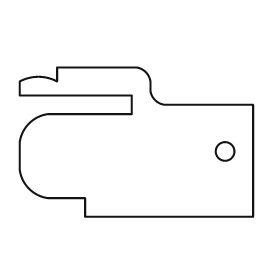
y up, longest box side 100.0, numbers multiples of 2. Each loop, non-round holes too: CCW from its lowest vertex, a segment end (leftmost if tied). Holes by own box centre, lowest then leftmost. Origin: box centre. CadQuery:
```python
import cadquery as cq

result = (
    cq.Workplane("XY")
    .moveTo(-22.0, -32.0)
    .lineTo(50.0, -32.0)
    .lineTo(50.0, 16.0)
    .lineTo(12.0, 16.0)
    .threePointArc((8.0, 18.0), (6.0, 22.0))
    .lineTo(6.0, 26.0)
    .threePointArc((4.0, 30.0), (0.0, 32.0))
    .lineTo(-34.0, 32.0)
    .lineTo(-34.0, 26.0)
    .threePointArc((-42.0, 28.0), (-50.0, 26.0))
    .lineTo(-50.0, 20.0)
    .lineTo(-2.0, 20.0)
    .lineTo(-2.0, 12.0)
    .lineTo(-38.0, 12.0)
    .threePointArc((-46.0, 8.0), (-50.0, 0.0))
    .lineTo(-50.0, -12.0)
    .threePointArc((-46.0, -20.0), (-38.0, -24.0))
    .lineTo(-22.0, -24.0)
    .close()
    .moveTo(38.0, -4.0)
    .circle(4.0)
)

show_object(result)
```